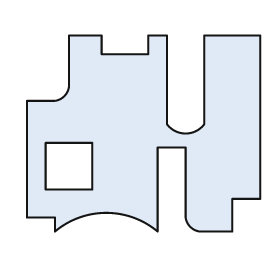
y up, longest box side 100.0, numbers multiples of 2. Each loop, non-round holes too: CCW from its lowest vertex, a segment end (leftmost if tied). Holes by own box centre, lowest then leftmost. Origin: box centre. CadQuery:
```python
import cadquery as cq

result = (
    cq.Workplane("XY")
    .moveTo(-38.0, -42.0)
    .threePointArc((-16.0, -34.0), (6.0, -42.0))
    .lineTo(6.0, -6.0)
    .lineTo(18.0, -6.0)
    .lineTo(18.0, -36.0)
    .threePointArc((20.0, -40.0), (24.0, -42.0))
    .lineTo(38.0, -42.0)
    .lineTo(38.0, -28.0)
    .lineTo(50.0, -28.0)
    .lineTo(50.0, 42.0)
    .lineTo(26.0, 42.0)
    .lineTo(26.0, 4.0)
    .threePointArc((18.0, 0.0), (10.0, 4.0))
    .lineTo(10.0, 42.0)
    .lineTo(2.0, 42.0)
    .lineTo(2.0, 34.0)
    .lineTo(-18.0, 34.0)
    .lineTo(-18.0, 42.0)
    .lineTo(-32.0, 42.0)
    .lineTo(-32.0, 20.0)
    .threePointArc((-34.0, 16.0), (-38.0, 14.0))
    .lineTo(-50.0, 14.0)
    .lineTo(-50.0, -36.0)
    .lineTo(-38.0, -36.0)
    .close()
    .moveTo(-42.0, -24.0)
    .lineTo(-22.0, -24.0)
    .lineTo(-22.0, -4.0)
    .lineTo(-42.0, -4.0)
    .close()
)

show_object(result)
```